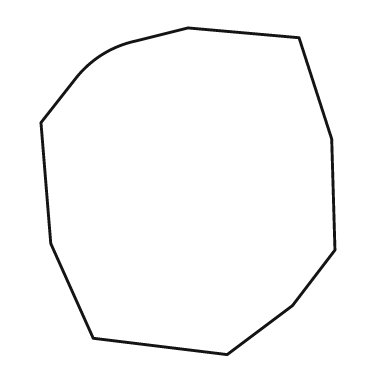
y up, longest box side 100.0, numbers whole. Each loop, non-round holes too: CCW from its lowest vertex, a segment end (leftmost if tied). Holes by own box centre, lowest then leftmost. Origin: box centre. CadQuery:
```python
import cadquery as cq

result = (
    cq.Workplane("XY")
    .moveTo(12.0, -50.0)
    .lineTo(32.0, -35.0)
    .lineTo(45.0, -18.0)
    .lineTo(44.0, 16.0)
    .lineTo(34.0, 47.0)
    .lineTo(0.0, 50.0)
    .lineTo(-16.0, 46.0)
    .threePointArc((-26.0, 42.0), (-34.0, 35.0))
    .lineTo(-45.0, 21.0)
    .lineTo(-42.0, -16.0)
    .lineTo(-29.0, -45.0)
    .close()
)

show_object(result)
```